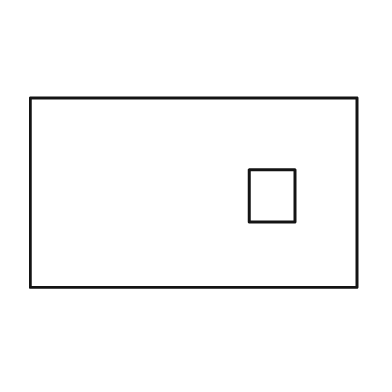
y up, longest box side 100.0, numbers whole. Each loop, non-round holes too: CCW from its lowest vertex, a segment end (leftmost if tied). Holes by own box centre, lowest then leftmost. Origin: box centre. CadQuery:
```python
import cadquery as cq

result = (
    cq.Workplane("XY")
    .moveTo(-50.0, -29.0)
    .lineTo(50.0, -29.0)
    .lineTo(50.0, 29.0)
    .lineTo(-50.0, 29.0)
    .close()
    .moveTo(17.0, -9.0)
    .lineTo(31.0, -9.0)
    .lineTo(31.0, 7.0)
    .lineTo(17.0, 7.0)
    .close()
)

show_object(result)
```